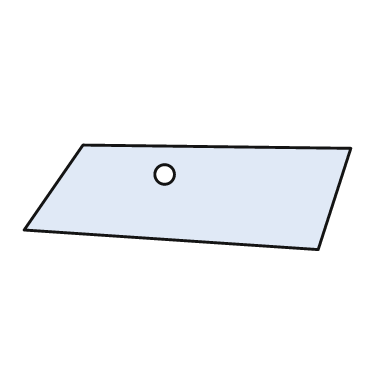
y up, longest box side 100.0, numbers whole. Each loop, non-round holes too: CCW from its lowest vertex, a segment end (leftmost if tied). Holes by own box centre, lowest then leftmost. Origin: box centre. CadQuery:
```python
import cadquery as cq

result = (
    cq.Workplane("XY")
    .moveTo(40.0, -16.0)
    .lineTo(50.0, 15.0)
    .lineTo(-32.0, 16.0)
    .lineTo(-50.0, -10.0)
    .close()
    .moveTo(-7.0, 7.0)
    .circle(3.0)
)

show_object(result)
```